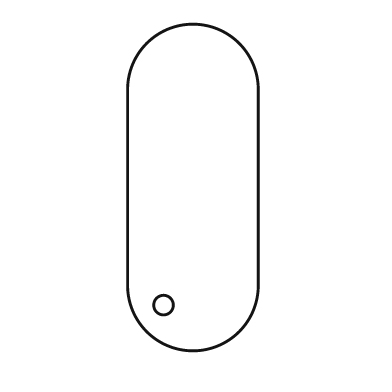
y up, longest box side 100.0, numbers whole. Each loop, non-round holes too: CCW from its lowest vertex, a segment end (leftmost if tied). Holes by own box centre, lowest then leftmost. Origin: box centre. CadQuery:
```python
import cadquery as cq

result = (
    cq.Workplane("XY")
    .moveTo(-20.0, -30.0)
    .threePointArc((0.0, -50.0), (20.0, -30.0))
    .lineTo(20.0, 30.0)
    .threePointArc((0.0, 50.0), (-20.0, 30.0))
    .close()
    .moveTo(-9.0, -36.0)
    .circle(3.0)
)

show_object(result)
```